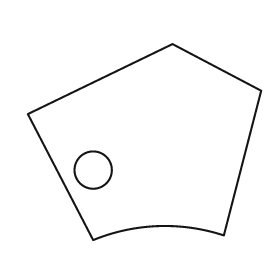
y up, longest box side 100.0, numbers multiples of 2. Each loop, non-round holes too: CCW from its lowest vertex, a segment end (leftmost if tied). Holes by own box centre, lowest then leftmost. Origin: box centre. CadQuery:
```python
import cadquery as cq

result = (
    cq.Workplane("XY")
    .moveTo(-22.0, -42.0)
    .threePointArc((6.0, -36.0), (34.0, -40.0))
    .lineTo(50.0, 22.0)
    .lineTo(12.0, 42.0)
    .lineTo(-50.0, 12.0)
    .close()
    .moveTo(-22.0, -12.0)
    .circle(8.0)
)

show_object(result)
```